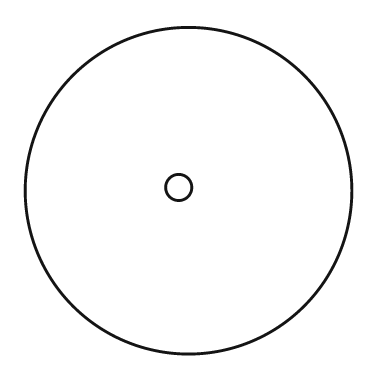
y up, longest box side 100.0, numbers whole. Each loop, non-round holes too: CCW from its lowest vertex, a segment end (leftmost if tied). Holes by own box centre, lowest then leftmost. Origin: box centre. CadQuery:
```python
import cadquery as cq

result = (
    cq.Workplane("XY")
    .moveTo(0.0, 0.0)
    .circle(50.0)
    .moveTo(-3.0, 1.0)
    .circle(4.0)
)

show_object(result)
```